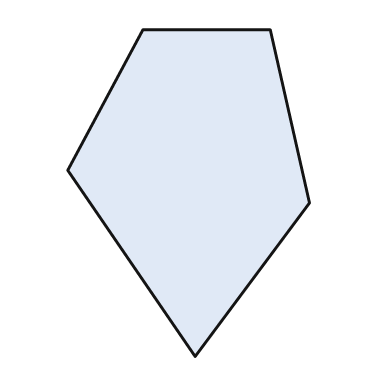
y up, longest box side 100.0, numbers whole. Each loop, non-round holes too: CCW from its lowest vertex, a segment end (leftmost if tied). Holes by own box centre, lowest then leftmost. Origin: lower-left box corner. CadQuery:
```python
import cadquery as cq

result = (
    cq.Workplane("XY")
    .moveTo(39.0, 0.0)
    .lineTo(74.0, 47.0)
    .lineTo(62.0, 100.0)
    .lineTo(23.0, 100.0)
    .lineTo(0.0, 57.0)
    .close()
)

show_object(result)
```